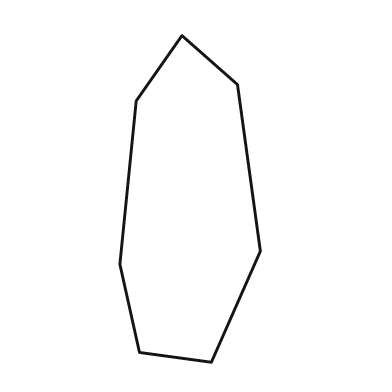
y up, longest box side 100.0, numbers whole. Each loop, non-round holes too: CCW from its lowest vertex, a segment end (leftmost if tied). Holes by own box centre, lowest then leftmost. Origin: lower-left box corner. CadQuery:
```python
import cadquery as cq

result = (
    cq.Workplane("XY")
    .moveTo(28.0, 0.0)
    .lineTo(43.0, 34.0)
    .lineTo(36.0, 85.0)
    .lineTo(19.0, 100.0)
    .lineTo(5.0, 80.0)
    .lineTo(0.0, 30.0)
    .lineTo(6.0, 3.0)
    .close()
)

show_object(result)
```